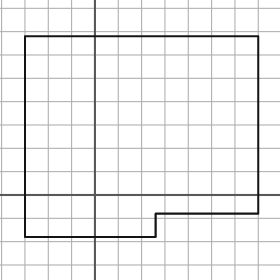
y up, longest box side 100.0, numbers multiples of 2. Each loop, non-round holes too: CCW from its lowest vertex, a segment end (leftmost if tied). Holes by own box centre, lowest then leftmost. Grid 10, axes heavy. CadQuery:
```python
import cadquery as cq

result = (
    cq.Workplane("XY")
    .moveTo(-30.0, -18.0)
    .lineTo(26.0, -18.0)
    .lineTo(26.0, -8.0)
    .lineTo(70.0, -8.0)
    .lineTo(70.0, 68.0)
    .lineTo(-30.0, 68.0)
    .close()
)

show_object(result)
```